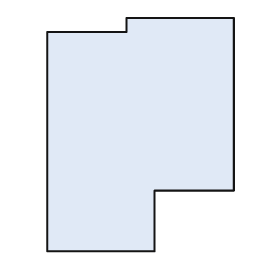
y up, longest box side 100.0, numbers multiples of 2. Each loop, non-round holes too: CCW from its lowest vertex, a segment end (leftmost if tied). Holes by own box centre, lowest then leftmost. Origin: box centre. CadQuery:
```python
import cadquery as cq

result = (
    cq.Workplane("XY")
    .moveTo(-40.0, -50.0)
    .lineTo(6.0, -50.0)
    .lineTo(6.0, -24.0)
    .lineTo(40.0, -24.0)
    .lineTo(40.0, 50.0)
    .lineTo(-6.0, 50.0)
    .lineTo(-6.0, 44.0)
    .lineTo(-40.0, 44.0)
    .close()
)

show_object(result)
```